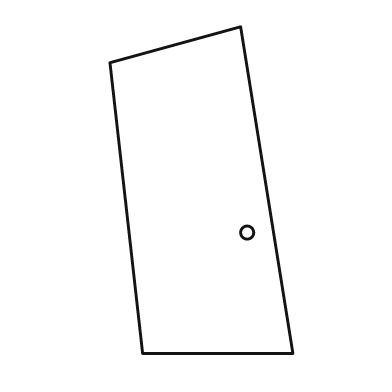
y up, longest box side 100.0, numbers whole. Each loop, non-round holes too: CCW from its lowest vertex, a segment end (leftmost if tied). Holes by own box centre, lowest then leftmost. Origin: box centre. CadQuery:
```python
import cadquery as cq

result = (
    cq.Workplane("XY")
    .moveTo(-18.0, -50.0)
    .lineTo(28.0, -50.0)
    .lineTo(12.0, 50.0)
    .lineTo(-28.0, 39.0)
    .close()
    .moveTo(14.0, -13.0)
    .circle(2.0)
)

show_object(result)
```